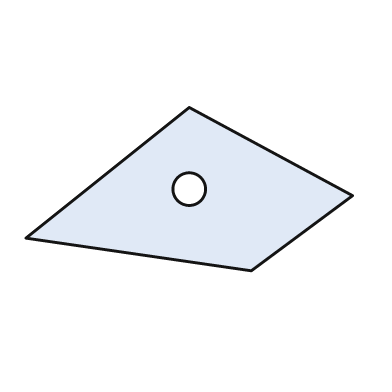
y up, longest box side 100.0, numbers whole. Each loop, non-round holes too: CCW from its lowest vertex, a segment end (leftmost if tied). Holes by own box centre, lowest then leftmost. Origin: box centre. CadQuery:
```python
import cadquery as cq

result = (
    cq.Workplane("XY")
    .moveTo(19.0, -25.0)
    .lineTo(50.0, -2.0)
    .lineTo(0.0, 25.0)
    .lineTo(-50.0, -15.0)
    .close()
    .moveTo(0.0, 0.0)
    .circle(5.0)
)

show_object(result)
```